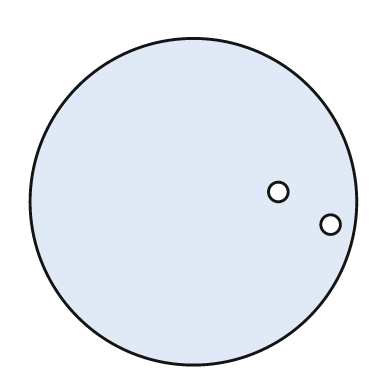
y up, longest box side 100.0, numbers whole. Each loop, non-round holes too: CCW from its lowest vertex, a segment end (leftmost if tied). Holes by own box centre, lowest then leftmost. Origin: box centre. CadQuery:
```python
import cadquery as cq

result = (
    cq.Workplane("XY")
    .moveTo(0.0, 0.0)
    .circle(50.0)
    .moveTo(42.0, -7.0)
    .circle(3.0)
    .moveTo(26.0, 3.0)
    .circle(3.0)
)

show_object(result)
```